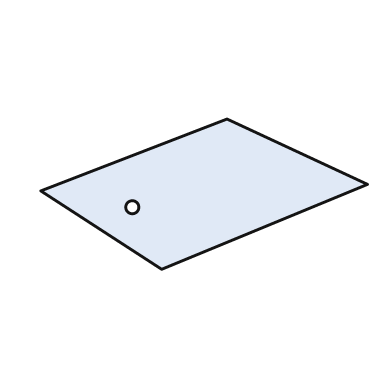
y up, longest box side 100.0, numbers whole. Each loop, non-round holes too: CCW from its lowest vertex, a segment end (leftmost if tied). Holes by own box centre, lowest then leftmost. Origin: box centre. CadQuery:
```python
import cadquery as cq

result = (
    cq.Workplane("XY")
    .moveTo(-13.0, -23.0)
    .lineTo(50.0, 3.0)
    .lineTo(7.0, 23.0)
    .lineTo(-50.0, 1.0)
    .close()
    .moveTo(-22.0, -4.0)
    .circle(2.0)
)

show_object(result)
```